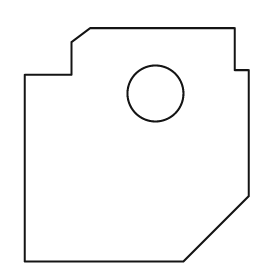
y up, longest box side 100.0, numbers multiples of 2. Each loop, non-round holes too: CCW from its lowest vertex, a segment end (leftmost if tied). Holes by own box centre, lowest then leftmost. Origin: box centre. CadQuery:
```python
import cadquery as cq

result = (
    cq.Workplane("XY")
    .moveTo(-48.0, -50.0)
    .lineTo(20.0, -50.0)
    .lineTo(48.0, -22.0)
    .lineTo(48.0, 32.0)
    .lineTo(42.0, 32.0)
    .lineTo(42.0, 50.0)
    .lineTo(-20.0, 50.0)
    .lineTo(-28.0, 44.0)
    .lineTo(-28.0, 30.0)
    .lineTo(-48.0, 30.0)
    .close()
    .moveTo(8.0, 22.0)
    .circle(12.0)
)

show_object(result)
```